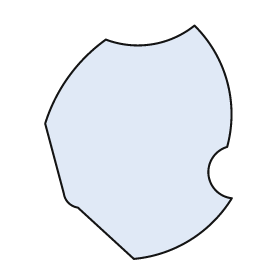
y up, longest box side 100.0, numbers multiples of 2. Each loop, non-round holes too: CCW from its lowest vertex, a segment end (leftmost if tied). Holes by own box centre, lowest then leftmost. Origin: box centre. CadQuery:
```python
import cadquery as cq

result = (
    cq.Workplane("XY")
    .moveTo(-2.0, -50.0)
    .threePointArc((22.0, -42.0), (40.0, -24.0))
    .threePointArc((30.0, -14.0), (38.0, -2.0))
    .threePointArc((38.0, 26.0), (24.0, 50.0))
    .threePointArc((6.0, 42.0), (-14.0, 44.0))
    .threePointArc((-30.0, 28.0), (-40.0, 8.0))
    .lineTo(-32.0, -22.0)
    .threePointArc((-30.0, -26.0), (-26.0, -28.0))
    .close()
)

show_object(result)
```